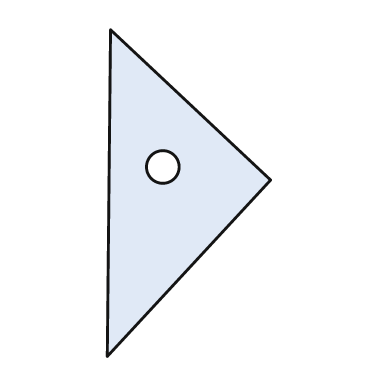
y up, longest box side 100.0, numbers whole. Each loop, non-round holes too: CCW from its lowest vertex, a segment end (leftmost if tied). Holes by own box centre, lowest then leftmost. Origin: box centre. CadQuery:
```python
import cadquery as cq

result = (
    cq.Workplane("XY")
    .moveTo(-25.0, -50.0)
    .lineTo(25.0, 4.0)
    .lineTo(-24.0, 50.0)
    .close()
    .moveTo(-8.0, 8.0)
    .circle(5.0)
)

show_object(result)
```